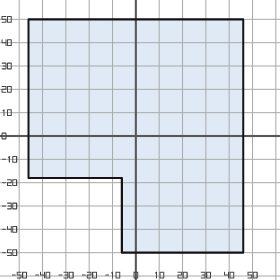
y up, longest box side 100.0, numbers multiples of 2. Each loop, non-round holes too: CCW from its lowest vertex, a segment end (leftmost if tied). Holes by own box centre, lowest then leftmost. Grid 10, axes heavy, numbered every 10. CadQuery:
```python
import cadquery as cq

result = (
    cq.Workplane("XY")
    .moveTo(-6.0, -50.0)
    .lineTo(46.0, -50.0)
    .lineTo(46.0, 50.0)
    .lineTo(-46.0, 50.0)
    .lineTo(-46.0, -18.0)
    .lineTo(-6.0, -18.0)
    .close()
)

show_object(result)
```